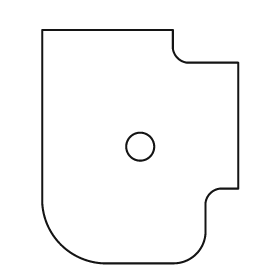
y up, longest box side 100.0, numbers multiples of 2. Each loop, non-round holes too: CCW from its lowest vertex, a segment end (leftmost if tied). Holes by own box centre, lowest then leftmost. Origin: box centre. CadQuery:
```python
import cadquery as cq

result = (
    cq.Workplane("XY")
    .moveTo(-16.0, -50.0)
    .lineTo(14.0, -50.0)
    .threePointArc((24.0, -46.0), (28.0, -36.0))
    .lineTo(28.0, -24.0)
    .threePointArc((30.0, -20.0), (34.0, -18.0))
    .lineTo(42.0, -18.0)
    .lineTo(42.0, 36.0)
    .lineTo(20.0, 36.0)
    .threePointArc((16.0, 38.0), (14.0, 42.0))
    .lineTo(14.0, 50.0)
    .lineTo(-42.0, 50.0)
    .lineTo(-42.0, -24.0)
    .threePointArc((-34.0, -42.0), (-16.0, -50.0))
    .close()
    .moveTo(0.0, 0.0)
    .circle(6.0)
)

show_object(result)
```